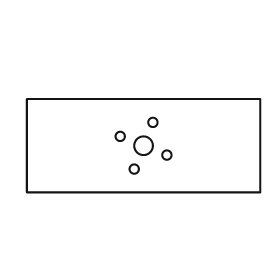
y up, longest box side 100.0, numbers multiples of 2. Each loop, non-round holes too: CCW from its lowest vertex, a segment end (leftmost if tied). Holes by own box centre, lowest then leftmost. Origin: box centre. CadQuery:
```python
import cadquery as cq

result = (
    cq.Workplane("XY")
    .moveTo(-50.0, -20.0)
    .lineTo(50.0, -20.0)
    .lineTo(50.0, 20.0)
    .lineTo(-50.0, 20.0)
    .close()
    .moveTo(-4.0, -10.0)
    .circle(2.0)
    .moveTo(10.0, -4.0)
    .circle(2.0)
    .moveTo(0.0, 0.0)
    .circle(4.0)
    .moveTo(-10.0, 4.0)
    .circle(2.0)
    .moveTo(4.0, 10.0)
    .circle(2.0)
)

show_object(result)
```